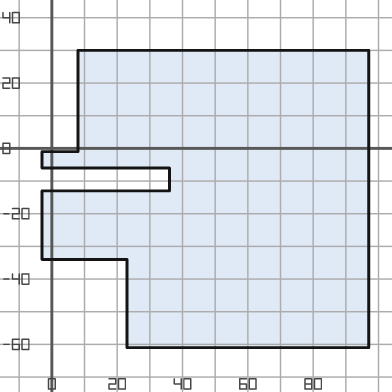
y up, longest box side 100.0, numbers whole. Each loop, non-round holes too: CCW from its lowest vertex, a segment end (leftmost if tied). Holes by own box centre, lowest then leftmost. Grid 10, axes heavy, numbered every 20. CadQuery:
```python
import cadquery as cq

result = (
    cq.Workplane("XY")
    .moveTo(23.0, -61.0)
    .lineTo(97.0, -61.0)
    .lineTo(97.0, 30.0)
    .lineTo(8.0, 30.0)
    .lineTo(8.0, -1.0)
    .lineTo(-3.0, -1.0)
    .lineTo(-3.0, -6.0)
    .lineTo(36.0, -6.0)
    .lineTo(36.0, -13.0)
    .lineTo(-3.0, -13.0)
    .lineTo(-3.0, -34.0)
    .lineTo(23.0, -34.0)
    .close()
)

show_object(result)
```